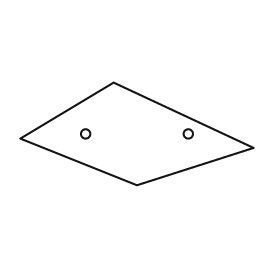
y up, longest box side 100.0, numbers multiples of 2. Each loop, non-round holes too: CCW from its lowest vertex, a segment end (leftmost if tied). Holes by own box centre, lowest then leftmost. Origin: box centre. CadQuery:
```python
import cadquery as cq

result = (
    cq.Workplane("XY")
    .moveTo(0.0, -22.0)
    .lineTo(50.0, -6.0)
    .lineTo(-10.0, 22.0)
    .lineTo(-50.0, -2.0)
    .close()
    .moveTo(-22.0, 0.0)
    .circle(2.0)
    .moveTo(22.0, 0.0)
    .circle(2.0)
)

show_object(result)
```